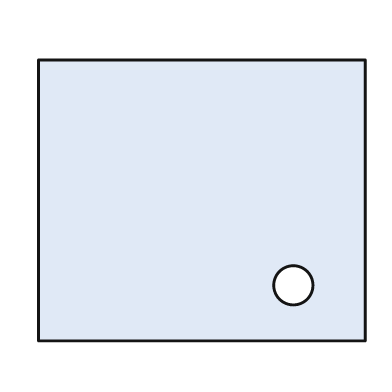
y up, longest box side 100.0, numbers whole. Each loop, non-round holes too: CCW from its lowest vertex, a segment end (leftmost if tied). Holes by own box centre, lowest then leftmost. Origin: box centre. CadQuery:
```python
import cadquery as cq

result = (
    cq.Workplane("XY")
    .moveTo(-50.0, -43.0)
    .lineTo(50.0, -43.0)
    .lineTo(50.0, 43.0)
    .lineTo(-50.0, 43.0)
    .close()
    .moveTo(28.0, -26.0)
    .circle(6.0)
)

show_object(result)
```